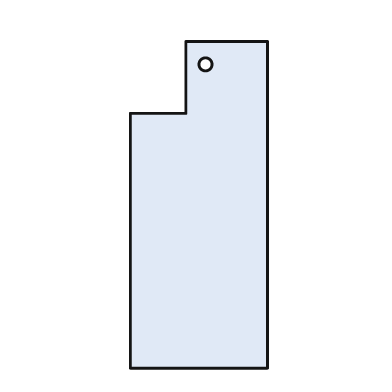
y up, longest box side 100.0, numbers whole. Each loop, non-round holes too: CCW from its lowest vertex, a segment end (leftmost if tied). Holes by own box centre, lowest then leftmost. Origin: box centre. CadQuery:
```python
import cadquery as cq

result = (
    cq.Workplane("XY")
    .moveTo(-21.0, -50.0)
    .lineTo(21.0, -50.0)
    .lineTo(21.0, 50.0)
    .lineTo(-4.0, 50.0)
    .lineTo(-4.0, 28.0)
    .lineTo(-21.0, 28.0)
    .close()
    .moveTo(2.0, 43.0)
    .circle(2.0)
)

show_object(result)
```